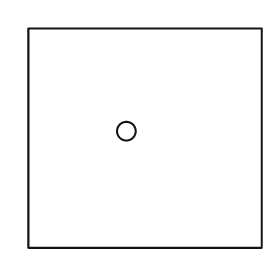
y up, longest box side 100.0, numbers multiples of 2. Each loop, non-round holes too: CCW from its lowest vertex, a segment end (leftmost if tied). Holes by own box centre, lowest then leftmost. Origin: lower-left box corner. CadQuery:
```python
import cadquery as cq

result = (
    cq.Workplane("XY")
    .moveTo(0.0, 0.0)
    .lineTo(100.0, 0.0)
    .lineTo(100.0, 94.0)
    .lineTo(0.0, 94.0)
    .close()
    .moveTo(42.0, 50.0)
    .circle(4.0)
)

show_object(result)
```